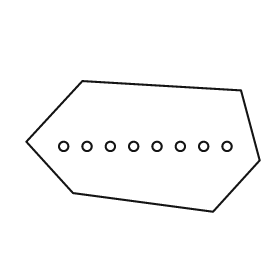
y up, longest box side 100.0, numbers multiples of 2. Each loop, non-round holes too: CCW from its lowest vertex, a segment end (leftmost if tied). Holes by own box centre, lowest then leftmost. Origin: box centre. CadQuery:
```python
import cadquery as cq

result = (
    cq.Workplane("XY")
    .moveTo(30.0, -28.0)
    .lineTo(50.0, -6.0)
    .lineTo(42.0, 24.0)
    .lineTo(-26.0, 28.0)
    .lineTo(-50.0, 2.0)
    .lineTo(-30.0, -20.0)
    .close()
    .moveTo(-34.0, 0.0)
    .circle(2.0)
    .moveTo(-24.0, 0.0)
    .circle(2.0)
    .moveTo(-14.0, 0.0)
    .circle(2.0)
    .moveTo(-4.0, 0.0)
    .circle(2.0)
    .moveTo(6.0, 0.0)
    .circle(2.0)
    .moveTo(16.0, 0.0)
    .circle(2.0)
    .moveTo(26.0, 0.0)
    .circle(2.0)
    .moveTo(36.0, 0.0)
    .circle(2.0)
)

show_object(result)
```